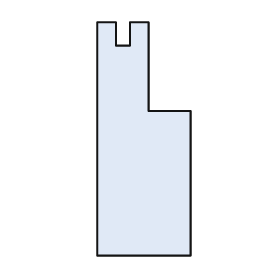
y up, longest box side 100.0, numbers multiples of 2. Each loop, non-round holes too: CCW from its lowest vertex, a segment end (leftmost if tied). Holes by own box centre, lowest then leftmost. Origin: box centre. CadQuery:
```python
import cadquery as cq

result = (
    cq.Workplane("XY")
    .moveTo(-20.0, -50.0)
    .lineTo(20.0, -50.0)
    .lineTo(20.0, 12.0)
    .lineTo(2.0, 12.0)
    .lineTo(2.0, 50.0)
    .lineTo(-6.0, 50.0)
    .lineTo(-6.0, 40.0)
    .lineTo(-12.0, 40.0)
    .lineTo(-12.0, 50.0)
    .lineTo(-20.0, 50.0)
    .close()
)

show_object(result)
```